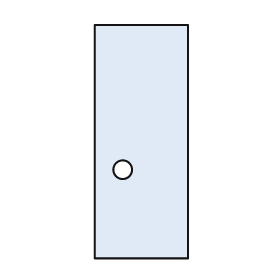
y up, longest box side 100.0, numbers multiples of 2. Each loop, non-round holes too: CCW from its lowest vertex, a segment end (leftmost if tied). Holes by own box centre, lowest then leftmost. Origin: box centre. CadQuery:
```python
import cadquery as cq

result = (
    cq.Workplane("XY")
    .moveTo(-20.0, -50.0)
    .lineTo(20.0, -50.0)
    .lineTo(20.0, 50.0)
    .lineTo(-20.0, 50.0)
    .close()
    .moveTo(-8.0, -12.0)
    .circle(4.0)
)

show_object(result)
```